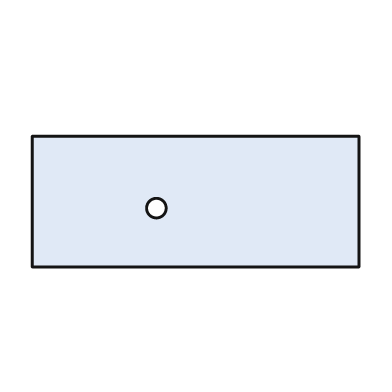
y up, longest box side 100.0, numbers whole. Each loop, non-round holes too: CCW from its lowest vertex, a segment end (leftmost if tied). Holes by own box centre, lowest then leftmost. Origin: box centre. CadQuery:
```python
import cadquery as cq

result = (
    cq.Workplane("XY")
    .moveTo(-50.0, -20.0)
    .lineTo(50.0, -20.0)
    .lineTo(50.0, 20.0)
    .lineTo(-50.0, 20.0)
    .close()
    .moveTo(-12.0, -2.0)
    .circle(3.0)
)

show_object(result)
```